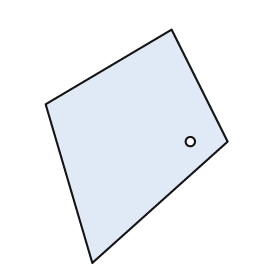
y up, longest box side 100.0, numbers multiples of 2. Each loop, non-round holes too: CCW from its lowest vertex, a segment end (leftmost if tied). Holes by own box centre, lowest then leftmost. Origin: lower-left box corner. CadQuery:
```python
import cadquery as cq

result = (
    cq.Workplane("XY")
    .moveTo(20.0, 0.0)
    .lineTo(78.0, 52.0)
    .lineTo(54.0, 100.0)
    .lineTo(0.0, 68.0)
    .close()
    .moveTo(62.0, 52.0)
    .circle(2.0)
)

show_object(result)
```